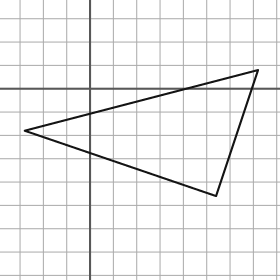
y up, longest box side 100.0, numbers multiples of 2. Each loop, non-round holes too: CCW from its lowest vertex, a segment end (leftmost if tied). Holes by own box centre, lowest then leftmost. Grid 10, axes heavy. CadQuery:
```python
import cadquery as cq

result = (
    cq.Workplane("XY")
    .moveTo(54.0, -46.0)
    .lineTo(72.0, 8.0)
    .lineTo(-28.0, -18.0)
    .close()
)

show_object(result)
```